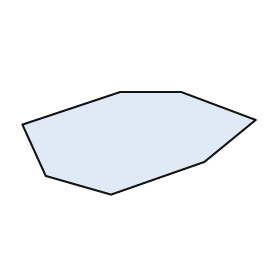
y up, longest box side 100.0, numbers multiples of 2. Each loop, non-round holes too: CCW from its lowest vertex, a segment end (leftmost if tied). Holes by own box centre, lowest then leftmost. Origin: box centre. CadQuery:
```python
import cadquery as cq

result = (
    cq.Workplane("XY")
    .moveTo(-12.0, -22.0)
    .lineTo(28.0, -8.0)
    .lineTo(50.0, 10.0)
    .lineTo(18.0, 22.0)
    .lineTo(-8.0, 22.0)
    .lineTo(-50.0, 8.0)
    .lineTo(-40.0, -14.0)
    .close()
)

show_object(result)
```